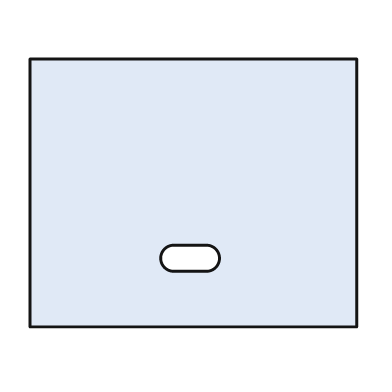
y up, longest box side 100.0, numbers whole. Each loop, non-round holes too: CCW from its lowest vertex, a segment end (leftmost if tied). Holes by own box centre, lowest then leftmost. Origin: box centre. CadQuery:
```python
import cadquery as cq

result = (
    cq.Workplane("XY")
    .moveTo(-50.0, -41.0)
    .lineTo(50.0, -41.0)
    .lineTo(50.0, 41.0)
    .lineTo(-50.0, 41.0)
    .close()
    .moveTo(-6.0, -24.0)
    .lineTo(4.0, -24.0)
    .threePointArc((8.0, -20.0), (4.0, -16.0))
    .lineTo(-6.0, -16.0)
    .threePointArc((-10.0, -20.0), (-6.0, -24.0))
    .close()
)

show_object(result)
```